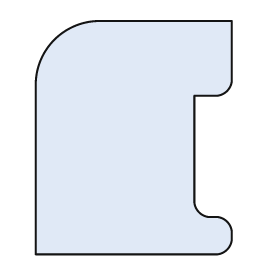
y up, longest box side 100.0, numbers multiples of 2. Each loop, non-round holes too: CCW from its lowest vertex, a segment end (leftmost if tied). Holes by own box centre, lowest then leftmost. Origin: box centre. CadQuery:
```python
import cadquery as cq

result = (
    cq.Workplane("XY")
    .moveTo(-42.0, -50.0)
    .lineTo(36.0, -50.0)
    .threePointArc((40.0, -48.0), (42.0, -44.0))
    .lineTo(42.0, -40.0)
    .threePointArc((40.0, -36.0), (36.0, -34.0))
    .lineTo(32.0, -34.0)
    .threePointArc((28.0, -32.0), (26.0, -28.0))
    .lineTo(26.0, 18.0)
    .lineTo(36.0, 18.0)
    .threePointArc((40.0, 20.0), (42.0, 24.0))
    .lineTo(42.0, 50.0)
    .lineTo(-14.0, 50.0)
    .threePointArc((-34.0, 42.0), (-42.0, 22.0))
    .close()
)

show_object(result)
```